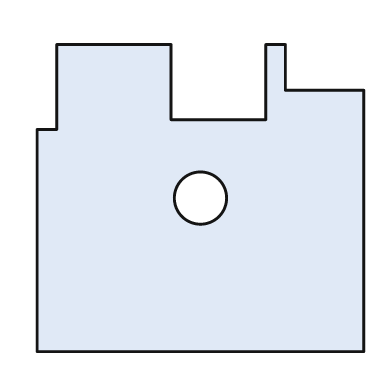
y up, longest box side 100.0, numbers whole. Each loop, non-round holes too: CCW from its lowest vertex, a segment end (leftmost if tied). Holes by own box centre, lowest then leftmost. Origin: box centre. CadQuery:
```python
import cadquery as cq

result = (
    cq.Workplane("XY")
    .moveTo(-50.0, -47.0)
    .lineTo(50.0, -47.0)
    .lineTo(50.0, 33.0)
    .lineTo(26.0, 33.0)
    .lineTo(26.0, 47.0)
    .lineTo(20.0, 47.0)
    .lineTo(20.0, 24.0)
    .lineTo(-9.0, 24.0)
    .lineTo(-9.0, 47.0)
    .lineTo(-44.0, 47.0)
    .lineTo(-44.0, 21.0)
    .lineTo(-50.0, 21.0)
    .close()
    .moveTo(0.0, 0.0)
    .circle(8.0)
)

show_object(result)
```